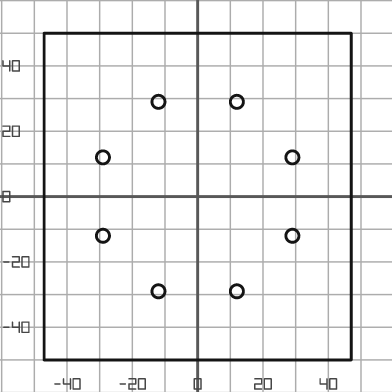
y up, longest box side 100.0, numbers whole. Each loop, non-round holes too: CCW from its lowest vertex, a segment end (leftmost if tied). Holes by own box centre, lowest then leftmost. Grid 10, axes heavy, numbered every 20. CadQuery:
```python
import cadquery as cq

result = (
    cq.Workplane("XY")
    .moveTo(-47.0, -50.0)
    .lineTo(47.0, -50.0)
    .lineTo(47.0, 50.0)
    .lineTo(-47.0, 50.0)
    .close()
    .moveTo(-12.0, -29.0)
    .circle(2.0)
    .moveTo(12.0, -29.0)
    .circle(2.0)
    .moveTo(-29.0, -12.0)
    .circle(2.0)
    .moveTo(29.0, -12.0)
    .circle(2.0)
    .moveTo(-29.0, 12.0)
    .circle(2.0)
    .moveTo(29.0, 12.0)
    .circle(2.0)
    .moveTo(-12.0, 29.0)
    .circle(2.0)
    .moveTo(12.0, 29.0)
    .circle(2.0)
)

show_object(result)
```